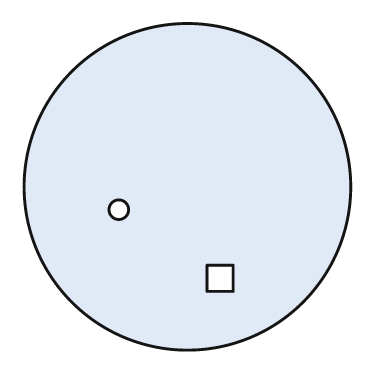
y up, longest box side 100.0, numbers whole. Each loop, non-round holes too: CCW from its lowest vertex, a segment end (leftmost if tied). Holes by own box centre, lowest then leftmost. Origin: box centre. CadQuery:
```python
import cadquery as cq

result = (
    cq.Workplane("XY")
    .moveTo(0.0, 0.0)
    .circle(50.0)
    .moveTo(6.0, -32.0)
    .lineTo(14.0, -32.0)
    .lineTo(14.0, -24.0)
    .lineTo(6.0, -24.0)
    .close()
    .moveTo(-21.0, -7.0)
    .circle(3.0)
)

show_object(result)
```